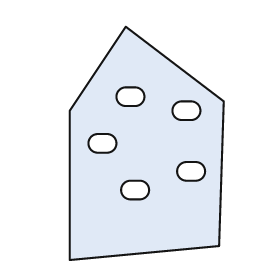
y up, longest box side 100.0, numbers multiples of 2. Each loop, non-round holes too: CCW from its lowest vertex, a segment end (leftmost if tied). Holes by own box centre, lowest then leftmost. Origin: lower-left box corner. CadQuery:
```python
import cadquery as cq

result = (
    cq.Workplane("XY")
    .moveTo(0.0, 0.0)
    .lineTo(64.0, 6.0)
    .lineTo(66.0, 68.0)
    .lineTo(24.0, 100.0)
    .lineTo(0.0, 64.0)
    .close()
    .moveTo(26.0, 26.0)
    .lineTo(30.0, 26.0)
    .threePointArc((34.0, 30.0), (30.0, 34.0))
    .lineTo(26.0, 34.0)
    .threePointArc((22.0, 30.0), (26.0, 26.0))
    .close()
    .moveTo(50.0, 34.0)
    .lineTo(54.0, 34.0)
    .threePointArc((58.0, 38.0), (54.0, 42.0))
    .lineTo(50.0, 42.0)
    .threePointArc((46.0, 38.0), (50.0, 34.0))
    .close()
    .moveTo(12.0, 46.0)
    .lineTo(16.0, 46.0)
    .threePointArc((20.0, 50.0), (16.0, 54.0))
    .lineTo(12.0, 54.0)
    .threePointArc((8.0, 50.0), (12.0, 46.0))
    .close()
    .moveTo(48.0, 60.0)
    .lineTo(52.0, 60.0)
    .threePointArc((56.0, 64.0), (52.0, 68.0))
    .lineTo(48.0, 68.0)
    .threePointArc((44.0, 64.0), (48.0, 60.0))
    .close()
    .moveTo(24.0, 66.0)
    .lineTo(28.0, 66.0)
    .threePointArc((32.0, 70.0), (28.0, 74.0))
    .lineTo(24.0, 74.0)
    .threePointArc((20.0, 70.0), (24.0, 66.0))
    .close()
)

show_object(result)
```